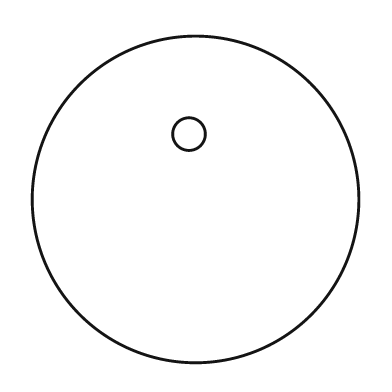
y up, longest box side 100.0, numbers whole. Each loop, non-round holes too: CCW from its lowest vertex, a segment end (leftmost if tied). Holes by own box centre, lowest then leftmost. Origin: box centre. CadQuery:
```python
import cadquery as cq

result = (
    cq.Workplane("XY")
    .moveTo(0.0, 0.0)
    .circle(50.0)
    .moveTo(-2.0, 20.0)
    .circle(5.0)
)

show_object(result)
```